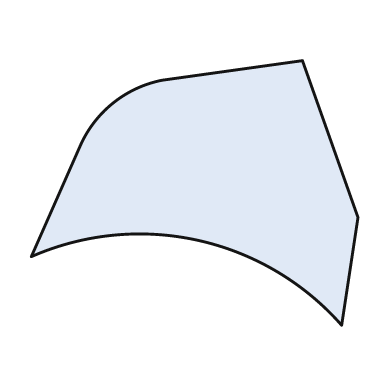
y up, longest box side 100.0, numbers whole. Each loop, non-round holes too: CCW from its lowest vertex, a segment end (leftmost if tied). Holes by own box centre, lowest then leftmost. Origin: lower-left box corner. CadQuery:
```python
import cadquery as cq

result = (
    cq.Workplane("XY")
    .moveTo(95.0, 0.0)
    .lineTo(100.0, 33.0)
    .lineTo(83.0, 81.0)
    .lineTo(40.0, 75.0)
    .threePointArc((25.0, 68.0), (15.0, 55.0))
    .lineTo(0.0, 21.0)
    .threePointArc((51.0, 26.0), (95.0, 0.0))
    .close()
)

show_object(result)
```